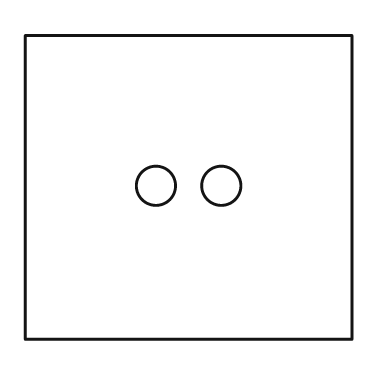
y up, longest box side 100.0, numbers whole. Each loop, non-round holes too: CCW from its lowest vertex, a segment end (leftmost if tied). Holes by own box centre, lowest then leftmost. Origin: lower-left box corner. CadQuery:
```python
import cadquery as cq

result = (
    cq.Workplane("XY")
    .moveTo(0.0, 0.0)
    .lineTo(100.0, 0.0)
    .lineTo(100.0, 93.0)
    .lineTo(0.0, 93.0)
    .close()
    .moveTo(40.0, 47.0)
    .circle(6.0)
    .moveTo(60.0, 47.0)
    .circle(6.0)
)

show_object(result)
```